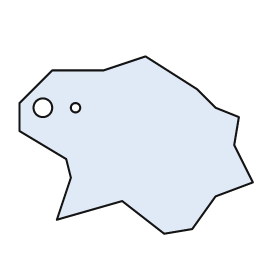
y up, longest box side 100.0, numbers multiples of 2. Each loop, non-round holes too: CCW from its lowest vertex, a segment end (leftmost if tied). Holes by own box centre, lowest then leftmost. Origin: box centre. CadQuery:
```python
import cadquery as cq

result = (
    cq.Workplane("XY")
    .moveTo(12.0, -38.0)
    .lineTo(24.0, -36.0)
    .lineTo(34.0, -22.0)
    .lineTo(50.0, -16.0)
    .lineTo(42.0, 0.0)
    .lineTo(44.0, 12.0)
    .lineTo(34.0, 16.0)
    .lineTo(26.0, 24.0)
    .lineTo(4.0, 38.0)
    .lineTo(-14.0, 32.0)
    .lineTo(-36.0, 32.0)
    .lineTo(-50.0, 18.0)
    .lineTo(-50.0, 6.0)
    .lineTo(-30.0, -6.0)
    .lineTo(-28.0, -14.0)
    .lineTo(-34.0, -32.0)
    .lineTo(-6.0, -24.0)
    .close()
    .moveTo(-40.0, 16.0)
    .circle(4.0)
    .moveTo(-26.0, 16.0)
    .circle(2.0)
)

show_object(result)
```